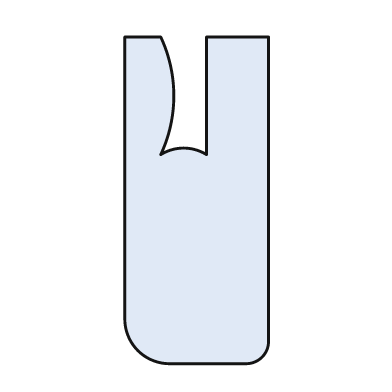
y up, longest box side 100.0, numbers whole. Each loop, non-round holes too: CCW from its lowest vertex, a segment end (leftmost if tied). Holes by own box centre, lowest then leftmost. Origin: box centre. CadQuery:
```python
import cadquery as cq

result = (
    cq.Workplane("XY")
    .moveTo(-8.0, -50.0)
    .lineTo(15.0, -50.0)
    .threePointArc((20.0, -48.0), (22.0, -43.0))
    .lineTo(22.0, 50.0)
    .lineTo(3.0, 50.0)
    .lineTo(3.0, 14.0)
    .threePointArc((-4.0, 16.0), (-11.0, 14.0))
    .threePointArc((-7.0, 32.0), (-11.0, 50.0))
    .lineTo(-22.0, 50.0)
    .lineTo(-22.0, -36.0)
    .threePointArc((-18.0, -46.0), (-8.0, -50.0))
    .close()
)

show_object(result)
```